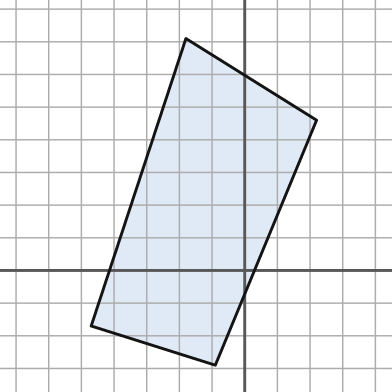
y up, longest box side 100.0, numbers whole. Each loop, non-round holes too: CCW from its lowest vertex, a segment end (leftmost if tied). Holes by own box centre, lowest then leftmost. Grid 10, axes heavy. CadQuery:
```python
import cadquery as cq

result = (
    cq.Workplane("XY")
    .moveTo(-9.0, -29.0)
    .lineTo(22.0, 46.0)
    .lineTo(-18.0, 71.0)
    .lineTo(-47.0, -17.0)
    .close()
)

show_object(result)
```